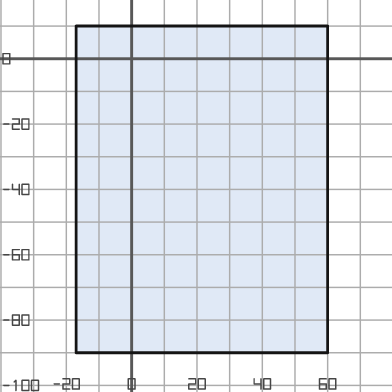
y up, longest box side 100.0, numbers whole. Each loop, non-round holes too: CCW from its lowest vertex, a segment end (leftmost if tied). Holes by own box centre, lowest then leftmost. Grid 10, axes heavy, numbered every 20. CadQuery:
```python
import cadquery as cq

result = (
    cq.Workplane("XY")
    .moveTo(-17.0, -90.0)
    .lineTo(60.0, -90.0)
    .lineTo(60.0, 10.0)
    .lineTo(-17.0, 10.0)
    .close()
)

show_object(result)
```